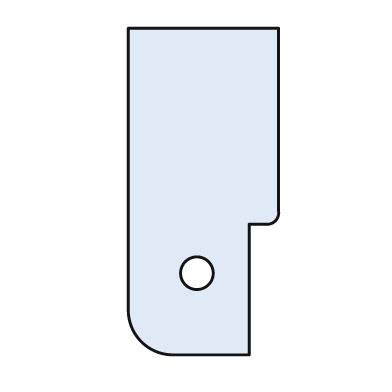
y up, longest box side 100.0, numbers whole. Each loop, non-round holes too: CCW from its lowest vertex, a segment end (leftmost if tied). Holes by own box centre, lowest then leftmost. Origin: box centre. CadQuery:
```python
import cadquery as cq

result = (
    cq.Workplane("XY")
    .moveTo(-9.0, -50.0)
    .lineTo(14.0, -50.0)
    .lineTo(14.0, -10.0)
    .lineTo(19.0, -10.0)
    .threePointArc((22.0, -9.0), (23.0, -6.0))
    .lineTo(23.0, 50.0)
    .lineTo(-23.0, 50.0)
    .lineTo(-23.0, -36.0)
    .threePointArc((-19.0, -46.0), (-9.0, -50.0))
    .close()
    .moveTo(-2.0, -25.0)
    .circle(5.0)
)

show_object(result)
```